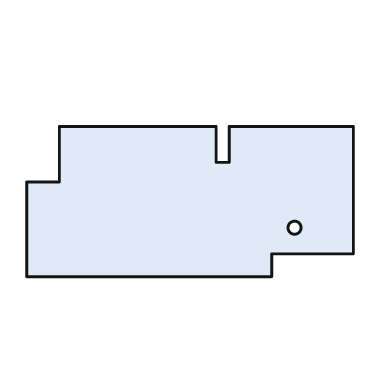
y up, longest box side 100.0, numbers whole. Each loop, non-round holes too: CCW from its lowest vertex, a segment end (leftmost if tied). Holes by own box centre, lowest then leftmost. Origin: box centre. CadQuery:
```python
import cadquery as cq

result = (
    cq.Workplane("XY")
    .moveTo(-50.0, -23.0)
    .lineTo(25.0, -23.0)
    .lineTo(25.0, -16.0)
    .lineTo(50.0, -16.0)
    .lineTo(50.0, 23.0)
    .lineTo(12.0, 23.0)
    .lineTo(12.0, 12.0)
    .lineTo(8.0, 12.0)
    .lineTo(8.0, 23.0)
    .lineTo(-40.0, 23.0)
    .lineTo(-40.0, 6.0)
    .lineTo(-50.0, 6.0)
    .close()
    .moveTo(32.0, -8.0)
    .circle(2.0)
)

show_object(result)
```